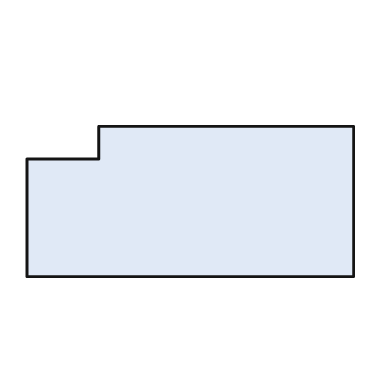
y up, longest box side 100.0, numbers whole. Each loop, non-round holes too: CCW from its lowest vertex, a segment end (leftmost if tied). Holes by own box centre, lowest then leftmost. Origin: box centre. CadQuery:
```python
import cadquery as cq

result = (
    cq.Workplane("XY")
    .moveTo(-50.0, -23.0)
    .lineTo(50.0, -23.0)
    .lineTo(50.0, 23.0)
    .lineTo(-28.0, 23.0)
    .lineTo(-28.0, 13.0)
    .lineTo(-50.0, 13.0)
    .close()
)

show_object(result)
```